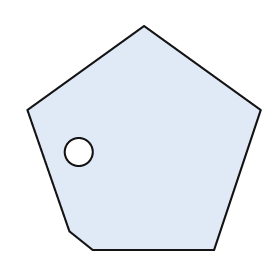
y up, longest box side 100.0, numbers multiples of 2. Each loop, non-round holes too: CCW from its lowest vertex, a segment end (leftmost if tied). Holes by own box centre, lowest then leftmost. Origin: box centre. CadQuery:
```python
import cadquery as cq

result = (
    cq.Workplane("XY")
    .moveTo(-22.0, -48.0)
    .lineTo(30.0, -48.0)
    .lineTo(50.0, 12.0)
    .lineTo(0.0, 48.0)
    .lineTo(-50.0, 12.0)
    .lineTo(-32.0, -40.0)
    .close()
    .moveTo(-28.0, -6.0)
    .circle(6.0)
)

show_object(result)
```